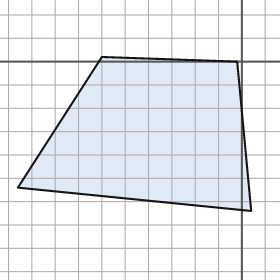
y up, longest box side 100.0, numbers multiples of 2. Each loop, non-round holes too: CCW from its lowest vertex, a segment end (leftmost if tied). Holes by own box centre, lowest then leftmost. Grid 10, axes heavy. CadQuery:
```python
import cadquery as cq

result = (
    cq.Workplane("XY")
    .moveTo(4.0, -64.0)
    .lineTo(-2.0, 0.0)
    .lineTo(-60.0, 2.0)
    .lineTo(-96.0, -54.0)
    .close()
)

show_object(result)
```